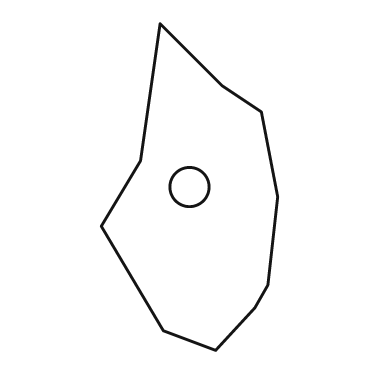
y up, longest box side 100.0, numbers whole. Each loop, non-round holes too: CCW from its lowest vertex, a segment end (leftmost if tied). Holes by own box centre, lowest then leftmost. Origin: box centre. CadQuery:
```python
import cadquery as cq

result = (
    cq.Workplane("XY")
    .moveTo(8.0, -50.0)
    .lineTo(20.0, -37.0)
    .lineTo(24.0, -30.0)
    .lineTo(27.0, -3.0)
    .lineTo(22.0, 23.0)
    .lineTo(10.0, 31.0)
    .lineTo(-9.0, 50.0)
    .lineTo(-15.0, 8.0)
    .lineTo(-27.0, -12.0)
    .lineTo(-8.0, -44.0)
    .close()
    .moveTo(0.0, 0.0)
    .circle(6.0)
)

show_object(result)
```